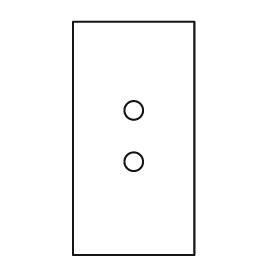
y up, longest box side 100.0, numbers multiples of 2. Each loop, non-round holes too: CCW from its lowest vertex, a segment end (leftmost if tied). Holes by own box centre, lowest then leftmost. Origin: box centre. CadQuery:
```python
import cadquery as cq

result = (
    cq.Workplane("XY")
    .moveTo(-26.0, -50.0)
    .lineTo(26.0, -50.0)
    .lineTo(26.0, 50.0)
    .lineTo(-26.0, 50.0)
    .close()
    .moveTo(0.0, -10.0)
    .circle(4.0)
    .moveTo(0.0, 12.0)
    .circle(4.0)
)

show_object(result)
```